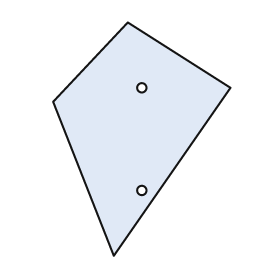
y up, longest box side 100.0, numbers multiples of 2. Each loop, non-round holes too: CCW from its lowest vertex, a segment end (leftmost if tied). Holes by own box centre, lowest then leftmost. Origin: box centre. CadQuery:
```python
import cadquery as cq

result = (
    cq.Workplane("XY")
    .moveTo(-12.0, -50.0)
    .lineTo(38.0, 22.0)
    .lineTo(-6.0, 50.0)
    .lineTo(-38.0, 16.0)
    .close()
    .moveTo(0.0, -22.0)
    .circle(2.0)
    .moveTo(0.0, 22.0)
    .circle(2.0)
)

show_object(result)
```